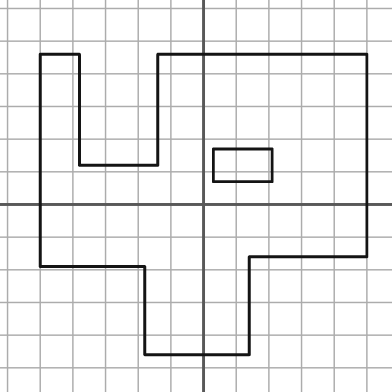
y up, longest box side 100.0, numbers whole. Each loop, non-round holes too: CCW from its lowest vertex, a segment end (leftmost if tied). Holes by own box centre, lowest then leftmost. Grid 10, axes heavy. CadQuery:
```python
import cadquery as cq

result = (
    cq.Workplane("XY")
    .moveTo(-18.0, -46.0)
    .lineTo(14.0, -46.0)
    .lineTo(14.0, -16.0)
    .lineTo(50.0, -16.0)
    .lineTo(50.0, 46.0)
    .lineTo(-14.0, 46.0)
    .lineTo(-14.0, 12.0)
    .lineTo(-38.0, 12.0)
    .lineTo(-38.0, 46.0)
    .lineTo(-50.0, 46.0)
    .lineTo(-50.0, -19.0)
    .lineTo(-18.0, -19.0)
    .close()
    .moveTo(3.0, 7.0)
    .lineTo(21.0, 7.0)
    .lineTo(21.0, 17.0)
    .lineTo(3.0, 17.0)
    .close()
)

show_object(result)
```